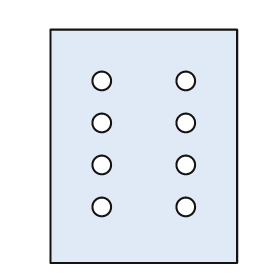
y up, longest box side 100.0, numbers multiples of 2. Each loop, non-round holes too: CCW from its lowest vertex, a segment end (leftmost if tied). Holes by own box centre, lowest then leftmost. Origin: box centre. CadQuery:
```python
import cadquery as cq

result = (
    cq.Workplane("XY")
    .moveTo(-40.0, -50.0)
    .lineTo(40.0, -50.0)
    .lineTo(40.0, 50.0)
    .lineTo(-40.0, 50.0)
    .close()
    .moveTo(-18.0, -26.0)
    .circle(4.0)
    .moveTo(18.0, -26.0)
    .circle(4.0)
    .moveTo(-18.0, -8.0)
    .circle(4.0)
    .moveTo(18.0, -8.0)
    .circle(4.0)
    .moveTo(-18.0, 10.0)
    .circle(4.0)
    .moveTo(18.0, 10.0)
    .circle(4.0)
    .moveTo(-18.0, 28.0)
    .circle(4.0)
    .moveTo(18.0, 28.0)
    .circle(4.0)
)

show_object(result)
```